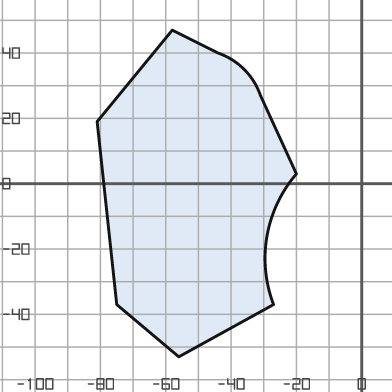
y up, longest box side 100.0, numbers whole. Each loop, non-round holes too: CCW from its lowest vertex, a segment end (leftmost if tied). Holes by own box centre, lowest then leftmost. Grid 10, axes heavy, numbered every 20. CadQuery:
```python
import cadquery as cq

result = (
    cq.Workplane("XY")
    .moveTo(-56.0, -53.0)
    .lineTo(-27.0, -37.0)
    .threePointArc((-29.0, -16.0), (-20.0, 3.0))
    .lineTo(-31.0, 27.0)
    .threePointArc((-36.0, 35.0), (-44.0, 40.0))
    .lineTo(-58.0, 47.0)
    .lineTo(-81.0, 19.0)
    .lineTo(-75.0, -37.0)
    .close()
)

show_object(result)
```